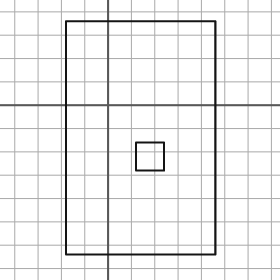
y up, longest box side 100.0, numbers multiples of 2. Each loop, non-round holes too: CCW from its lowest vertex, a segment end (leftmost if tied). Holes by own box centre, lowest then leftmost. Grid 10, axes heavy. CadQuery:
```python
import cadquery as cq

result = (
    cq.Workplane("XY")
    .moveTo(-18.0, -64.0)
    .lineTo(46.0, -64.0)
    .lineTo(46.0, 36.0)
    .lineTo(-18.0, 36.0)
    .close()
    .moveTo(12.0, -28.0)
    .lineTo(24.0, -28.0)
    .lineTo(24.0, -16.0)
    .lineTo(12.0, -16.0)
    .close()
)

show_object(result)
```